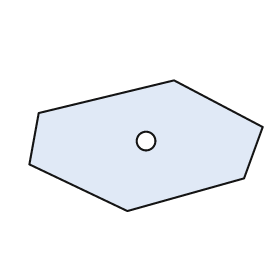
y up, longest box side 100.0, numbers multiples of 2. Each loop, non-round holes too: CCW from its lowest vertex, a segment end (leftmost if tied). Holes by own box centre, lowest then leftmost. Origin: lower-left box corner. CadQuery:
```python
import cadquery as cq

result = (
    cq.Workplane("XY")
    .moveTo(42.0, 0.0)
    .lineTo(92.0, 14.0)
    .lineTo(100.0, 36.0)
    .lineTo(62.0, 56.0)
    .lineTo(4.0, 42.0)
    .lineTo(0.0, 20.0)
    .close()
    .moveTo(50.0, 30.0)
    .circle(4.0)
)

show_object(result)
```